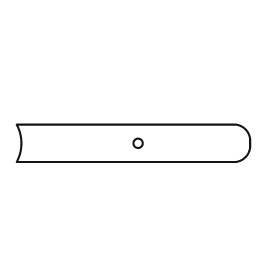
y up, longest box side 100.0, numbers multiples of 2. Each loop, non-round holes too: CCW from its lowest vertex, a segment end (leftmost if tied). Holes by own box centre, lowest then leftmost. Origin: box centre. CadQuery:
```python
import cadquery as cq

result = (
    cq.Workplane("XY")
    .moveTo(-50.0, -8.0)
    .lineTo(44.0, -8.0)
    .threePointArc((48.0, -6.0), (50.0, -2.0))
    .lineTo(50.0, 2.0)
    .threePointArc((48.0, 6.0), (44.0, 8.0))
    .lineTo(-50.0, 8.0)
    .threePointArc((-48.0, 0.0), (-50.0, -8.0))
    .close()
    .moveTo(2.0, 0.0)
    .circle(2.0)
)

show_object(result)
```